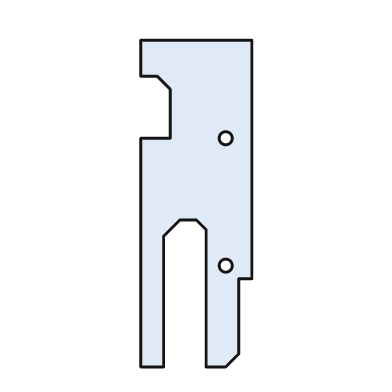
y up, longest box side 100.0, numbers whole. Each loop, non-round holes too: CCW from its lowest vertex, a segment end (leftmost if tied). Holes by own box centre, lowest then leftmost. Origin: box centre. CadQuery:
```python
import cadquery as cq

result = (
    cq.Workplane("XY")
    .moveTo(-17.0, -50.0)
    .lineTo(-10.0, -50.0)
    .lineTo(-10.0, -10.0)
    .lineTo(-5.0, -5.0)
    .lineTo(0.0, -5.0)
    .lineTo(3.0, -8.0)
    .lineTo(3.0, -50.0)
    .lineTo(9.0, -50.0)
    .lineTo(13.0, -46.0)
    .lineTo(13.0, -23.0)
    .lineTo(17.0, -23.0)
    .lineTo(17.0, 50.0)
    .lineTo(-17.0, 50.0)
    .lineTo(-17.0, 39.0)
    .lineTo(-12.0, 39.0)
    .lineTo(-8.0, 35.0)
    .lineTo(-8.0, 20.0)
    .lineTo(-17.0, 20.0)
    .close()
    .moveTo(9.0, -19.0)
    .circle(2.0)
    .moveTo(9.0, 20.0)
    .circle(2.0)
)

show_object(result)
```